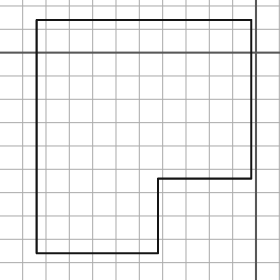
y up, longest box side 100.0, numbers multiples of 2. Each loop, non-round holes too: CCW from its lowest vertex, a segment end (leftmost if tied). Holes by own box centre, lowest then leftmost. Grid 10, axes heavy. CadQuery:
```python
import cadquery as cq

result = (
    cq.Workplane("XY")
    .moveTo(-94.0, -86.0)
    .lineTo(-42.0, -86.0)
    .lineTo(-42.0, -54.0)
    .lineTo(-2.0, -54.0)
    .lineTo(-2.0, 14.0)
    .lineTo(-94.0, 14.0)
    .close()
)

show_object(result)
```